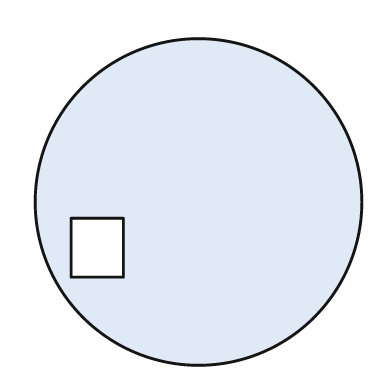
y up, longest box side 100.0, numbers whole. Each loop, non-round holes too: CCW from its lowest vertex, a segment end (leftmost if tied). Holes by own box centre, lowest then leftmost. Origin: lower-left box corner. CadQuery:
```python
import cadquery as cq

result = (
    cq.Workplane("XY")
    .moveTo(50.0, 50.0)
    .circle(50.0)
    .moveTo(11.0, 27.0)
    .lineTo(27.0, 27.0)
    .lineTo(27.0, 45.0)
    .lineTo(11.0, 45.0)
    .close()
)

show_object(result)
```